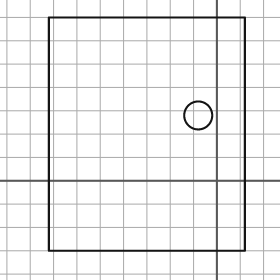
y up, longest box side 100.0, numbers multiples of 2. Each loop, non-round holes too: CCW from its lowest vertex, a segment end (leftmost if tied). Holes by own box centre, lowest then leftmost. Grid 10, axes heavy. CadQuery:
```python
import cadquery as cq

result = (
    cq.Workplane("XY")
    .moveTo(-72.0, -30.0)
    .lineTo(12.0, -30.0)
    .lineTo(12.0, 70.0)
    .lineTo(-72.0, 70.0)
    .close()
    .moveTo(-8.0, 28.0)
    .circle(6.0)
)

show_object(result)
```